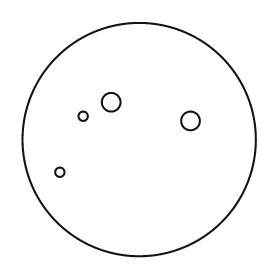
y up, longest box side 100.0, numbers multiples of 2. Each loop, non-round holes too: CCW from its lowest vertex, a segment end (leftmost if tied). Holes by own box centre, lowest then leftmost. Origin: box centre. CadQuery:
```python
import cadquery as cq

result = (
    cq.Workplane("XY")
    .moveTo(0.0, 0.0)
    .circle(50.0)
    .moveTo(-34.0, -14.0)
    .circle(2.0)
    .moveTo(22.0, 8.0)
    .circle(4.0)
    .moveTo(-24.0, 10.0)
    .circle(2.0)
    .moveTo(-12.0, 16.0)
    .circle(4.0)
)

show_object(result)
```